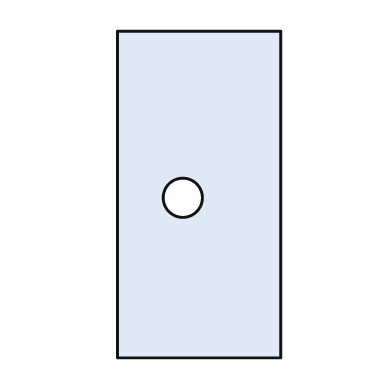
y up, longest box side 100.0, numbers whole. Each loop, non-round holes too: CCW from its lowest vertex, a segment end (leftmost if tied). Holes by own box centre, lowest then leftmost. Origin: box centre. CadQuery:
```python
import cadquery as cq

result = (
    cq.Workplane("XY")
    .moveTo(-25.0, -50.0)
    .lineTo(25.0, -50.0)
    .lineTo(25.0, 50.0)
    .lineTo(-25.0, 50.0)
    .close()
    .moveTo(-5.0, -1.0)
    .circle(6.0)
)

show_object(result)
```